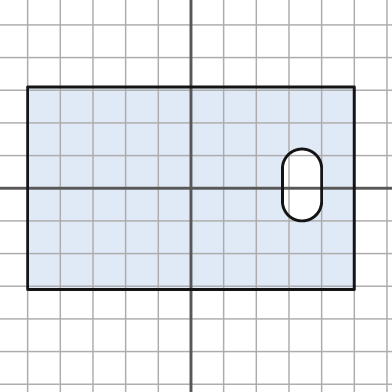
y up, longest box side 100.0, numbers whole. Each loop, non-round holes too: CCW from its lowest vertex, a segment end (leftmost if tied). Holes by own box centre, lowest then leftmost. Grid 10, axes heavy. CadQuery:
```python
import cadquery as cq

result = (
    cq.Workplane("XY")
    .moveTo(-50.0, -31.0)
    .lineTo(50.0, -31.0)
    .lineTo(50.0, 31.0)
    .lineTo(-50.0, 31.0)
    .close()
    .moveTo(28.0, -4.0)
    .threePointArc((34.0, -10.0), (40.0, -4.0))
    .lineTo(40.0, 6.0)
    .threePointArc((34.0, 12.0), (28.0, 6.0))
    .close()
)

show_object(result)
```